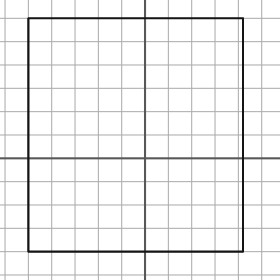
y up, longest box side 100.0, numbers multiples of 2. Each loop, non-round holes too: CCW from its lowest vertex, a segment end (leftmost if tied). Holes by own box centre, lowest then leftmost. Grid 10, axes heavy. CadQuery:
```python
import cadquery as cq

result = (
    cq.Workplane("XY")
    .moveTo(-50.0, -40.0)
    .lineTo(42.0, -40.0)
    .lineTo(42.0, 60.0)
    .lineTo(-50.0, 60.0)
    .close()
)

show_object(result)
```